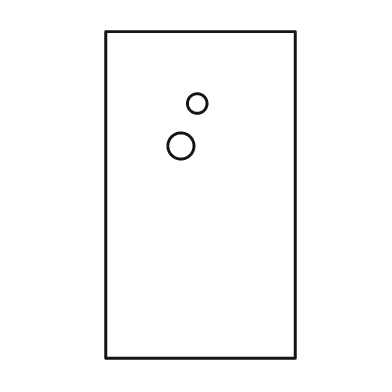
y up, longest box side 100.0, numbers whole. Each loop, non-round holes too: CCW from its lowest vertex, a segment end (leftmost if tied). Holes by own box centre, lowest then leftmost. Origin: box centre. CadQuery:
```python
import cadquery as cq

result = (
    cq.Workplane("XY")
    .moveTo(-29.0, -50.0)
    .lineTo(29.0, -50.0)
    .lineTo(29.0, 50.0)
    .lineTo(-29.0, 50.0)
    .close()
    .moveTo(-6.0, 15.0)
    .circle(4.0)
    .moveTo(-1.0, 28.0)
    .circle(3.0)
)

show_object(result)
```